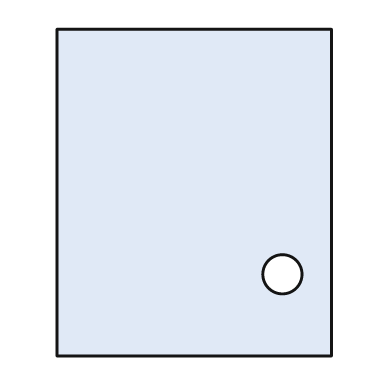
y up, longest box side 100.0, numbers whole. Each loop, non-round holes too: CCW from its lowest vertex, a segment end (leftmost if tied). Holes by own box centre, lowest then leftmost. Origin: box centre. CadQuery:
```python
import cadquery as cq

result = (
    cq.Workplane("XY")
    .moveTo(-42.0, -50.0)
    .lineTo(42.0, -50.0)
    .lineTo(42.0, 50.0)
    .lineTo(-42.0, 50.0)
    .close()
    .moveTo(27.0, -25.0)
    .circle(6.0)
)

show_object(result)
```